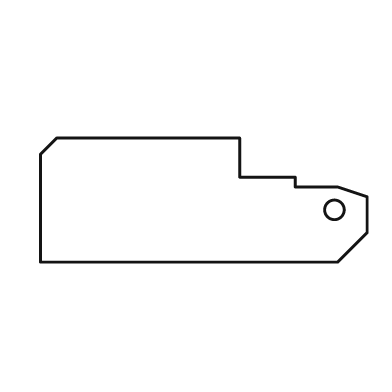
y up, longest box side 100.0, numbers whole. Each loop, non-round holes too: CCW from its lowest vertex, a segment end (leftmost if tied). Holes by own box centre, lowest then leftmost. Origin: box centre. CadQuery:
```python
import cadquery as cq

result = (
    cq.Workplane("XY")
    .moveTo(-50.0, -19.0)
    .lineTo(41.0, -19.0)
    .lineTo(50.0, -10.0)
    .lineTo(50.0, 1.0)
    .lineTo(41.0, 4.0)
    .lineTo(28.0, 4.0)
    .lineTo(28.0, 7.0)
    .lineTo(11.0, 7.0)
    .lineTo(11.0, 19.0)
    .lineTo(-45.0, 19.0)
    .lineTo(-50.0, 14.0)
    .close()
    .moveTo(40.0, -3.0)
    .circle(3.0)
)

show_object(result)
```